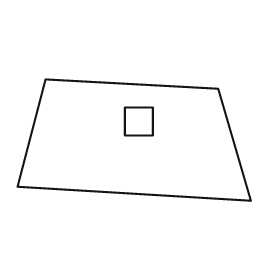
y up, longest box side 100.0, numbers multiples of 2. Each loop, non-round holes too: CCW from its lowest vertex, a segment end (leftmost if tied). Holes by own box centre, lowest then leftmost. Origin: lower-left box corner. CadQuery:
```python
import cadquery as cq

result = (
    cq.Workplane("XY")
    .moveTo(100.0, 0.0)
    .lineTo(86.0, 48.0)
    .lineTo(12.0, 52.0)
    .lineTo(0.0, 6.0)
    .close()
    .moveTo(46.0, 28.0)
    .lineTo(58.0, 28.0)
    .lineTo(58.0, 40.0)
    .lineTo(46.0, 40.0)
    .close()
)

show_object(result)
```